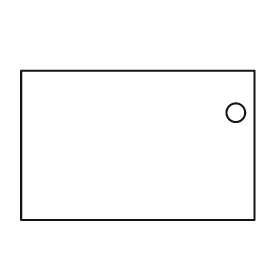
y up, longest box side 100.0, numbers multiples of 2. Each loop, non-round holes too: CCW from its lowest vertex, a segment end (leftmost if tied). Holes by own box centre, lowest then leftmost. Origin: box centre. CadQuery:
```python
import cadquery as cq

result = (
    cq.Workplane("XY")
    .moveTo(-50.0, -32.0)
    .lineTo(50.0, -32.0)
    .lineTo(50.0, 32.0)
    .lineTo(-50.0, 32.0)
    .close()
    .moveTo(42.0, 14.0)
    .circle(4.0)
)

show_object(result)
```